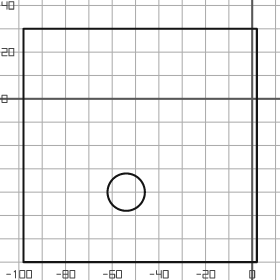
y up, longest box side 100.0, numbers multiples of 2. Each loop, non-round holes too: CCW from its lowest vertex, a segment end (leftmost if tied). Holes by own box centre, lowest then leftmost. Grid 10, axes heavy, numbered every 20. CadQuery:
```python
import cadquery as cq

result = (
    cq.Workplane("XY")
    .moveTo(-98.0, -70.0)
    .lineTo(2.0, -70.0)
    .lineTo(2.0, 30.0)
    .lineTo(-98.0, 30.0)
    .close()
    .moveTo(-54.0, -40.0)
    .circle(8.0)
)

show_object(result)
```